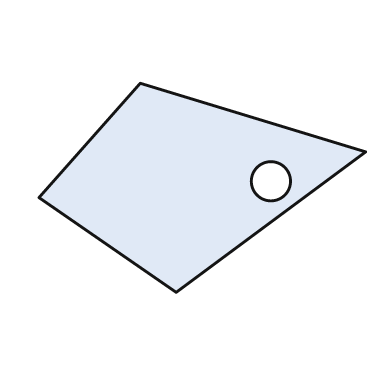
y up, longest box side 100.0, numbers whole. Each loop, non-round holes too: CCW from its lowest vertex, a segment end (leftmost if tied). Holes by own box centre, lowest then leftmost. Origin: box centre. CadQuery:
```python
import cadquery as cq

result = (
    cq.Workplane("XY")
    .moveTo(-8.0, -32.0)
    .lineTo(50.0, 11.0)
    .lineTo(-19.0, 32.0)
    .lineTo(-50.0, -3.0)
    .close()
    .moveTo(21.0, 2.0)
    .circle(6.0)
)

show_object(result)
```